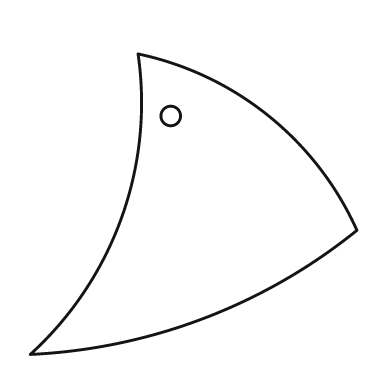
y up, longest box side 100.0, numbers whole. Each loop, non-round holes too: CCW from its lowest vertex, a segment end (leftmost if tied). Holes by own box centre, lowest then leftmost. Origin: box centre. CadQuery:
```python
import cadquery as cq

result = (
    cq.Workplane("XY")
    .moveTo(-50.0, -46.0)
    .threePointArc((3.0, -35.0), (50.0, -8.0))
    .threePointArc((23.0, 27.0), (-17.0, 46.0))
    .threePointArc((-22.0, -4.0), (-50.0, -46.0))
    .close()
    .moveTo(-7.0, 27.0)
    .circle(3.0)
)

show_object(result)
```